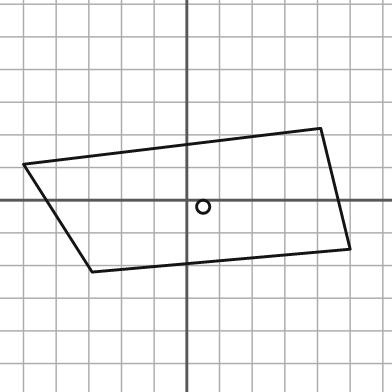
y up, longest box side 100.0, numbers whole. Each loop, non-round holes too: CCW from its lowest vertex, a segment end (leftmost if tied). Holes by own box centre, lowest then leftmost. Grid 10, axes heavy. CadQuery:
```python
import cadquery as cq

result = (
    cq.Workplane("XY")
    .moveTo(-29.0, -22.0)
    .lineTo(50.0, -15.0)
    .lineTo(41.0, 22.0)
    .lineTo(-50.0, 11.0)
    .close()
    .moveTo(5.0, -2.0)
    .circle(2.0)
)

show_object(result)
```